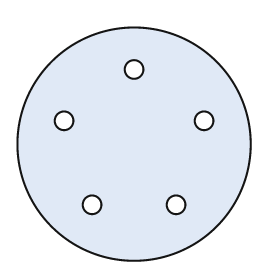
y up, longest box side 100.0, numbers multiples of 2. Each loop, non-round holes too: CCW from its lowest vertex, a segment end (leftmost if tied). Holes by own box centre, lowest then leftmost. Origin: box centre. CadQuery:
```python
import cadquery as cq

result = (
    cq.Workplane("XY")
    .moveTo(0.0, 0.0)
    .circle(50.0)
    .moveTo(-18.0, -26.0)
    .circle(4.0)
    .moveTo(18.0, -26.0)
    .circle(4.0)
    .moveTo(-30.0, 10.0)
    .circle(4.0)
    .moveTo(30.0, 10.0)
    .circle(4.0)
    .moveTo(0.0, 32.0)
    .circle(4.0)
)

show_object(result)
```